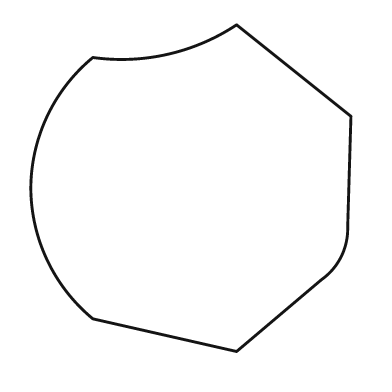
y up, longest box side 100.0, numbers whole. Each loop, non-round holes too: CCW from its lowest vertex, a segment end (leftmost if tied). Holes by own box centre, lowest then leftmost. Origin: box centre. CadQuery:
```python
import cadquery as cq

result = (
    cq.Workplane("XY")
    .moveTo(14.0, -50.0)
    .lineTo(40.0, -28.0)
    .threePointArc((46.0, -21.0), (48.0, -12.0))
    .lineTo(49.0, 22.0)
    .lineTo(14.0, 50.0)
    .threePointArc((-7.0, 41.0), (-30.0, 40.0))
    .threePointArc((-44.0, 22.0), (-49.0, 0.0))
    .threePointArc((-44.0, -22.0), (-30.0, -40.0))
    .close()
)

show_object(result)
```